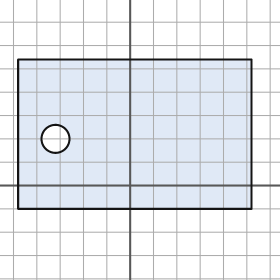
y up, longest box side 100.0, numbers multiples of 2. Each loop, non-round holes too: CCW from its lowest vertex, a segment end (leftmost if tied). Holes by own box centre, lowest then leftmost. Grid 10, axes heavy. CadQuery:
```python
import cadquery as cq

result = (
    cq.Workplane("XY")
    .moveTo(-48.0, -10.0)
    .lineTo(52.0, -10.0)
    .lineTo(52.0, 54.0)
    .lineTo(-48.0, 54.0)
    .close()
    .moveTo(-32.0, 20.0)
    .circle(6.0)
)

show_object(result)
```